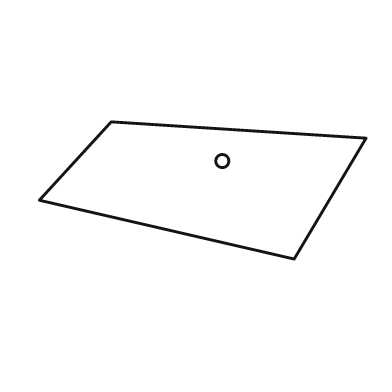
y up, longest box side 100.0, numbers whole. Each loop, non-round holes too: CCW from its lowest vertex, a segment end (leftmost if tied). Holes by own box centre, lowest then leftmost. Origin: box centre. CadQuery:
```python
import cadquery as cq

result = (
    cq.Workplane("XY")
    .moveTo(28.0, -21.0)
    .lineTo(50.0, 16.0)
    .lineTo(-28.0, 21.0)
    .lineTo(-50.0, -3.0)
    .close()
    .moveTo(6.0, 9.0)
    .circle(2.0)
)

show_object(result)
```